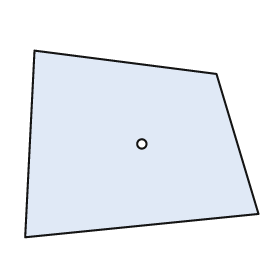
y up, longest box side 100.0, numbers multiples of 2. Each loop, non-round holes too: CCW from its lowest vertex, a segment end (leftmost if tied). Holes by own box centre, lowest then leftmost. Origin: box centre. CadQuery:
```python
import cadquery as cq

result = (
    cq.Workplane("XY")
    .moveTo(-50.0, -40.0)
    .lineTo(50.0, -30.0)
    .lineTo(32.0, 30.0)
    .lineTo(-46.0, 40.0)
    .close()
    .moveTo(0.0, 0.0)
    .circle(2.0)
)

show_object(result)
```